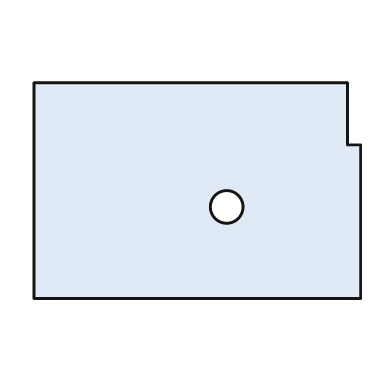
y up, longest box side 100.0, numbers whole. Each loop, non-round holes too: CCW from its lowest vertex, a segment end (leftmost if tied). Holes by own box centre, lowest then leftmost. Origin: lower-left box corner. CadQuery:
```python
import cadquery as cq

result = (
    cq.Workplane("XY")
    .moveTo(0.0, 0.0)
    .lineTo(100.0, 0.0)
    .lineTo(100.0, 47.0)
    .lineTo(96.0, 47.0)
    .lineTo(96.0, 66.0)
    .lineTo(0.0, 66.0)
    .close()
    .moveTo(59.0, 28.0)
    .circle(5.0)
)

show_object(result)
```